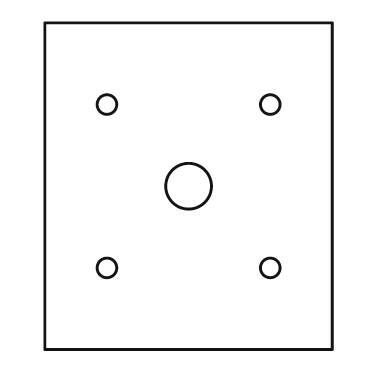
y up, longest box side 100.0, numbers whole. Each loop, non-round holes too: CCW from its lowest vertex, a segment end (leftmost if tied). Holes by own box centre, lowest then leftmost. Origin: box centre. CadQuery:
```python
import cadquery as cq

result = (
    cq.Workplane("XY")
    .moveTo(-44.0, -50.0)
    .lineTo(44.0, -50.0)
    .lineTo(44.0, 50.0)
    .lineTo(-44.0, 50.0)
    .close()
    .moveTo(-25.0, -25.0)
    .circle(3.0)
    .moveTo(25.0, -25.0)
    .circle(3.0)
    .moveTo(0.0, 0.0)
    .circle(7.0)
    .moveTo(-25.0, 25.0)
    .circle(3.0)
    .moveTo(25.0, 25.0)
    .circle(3.0)
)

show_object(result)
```